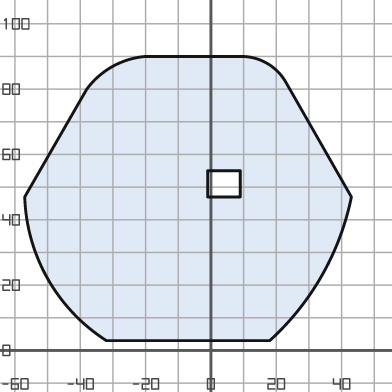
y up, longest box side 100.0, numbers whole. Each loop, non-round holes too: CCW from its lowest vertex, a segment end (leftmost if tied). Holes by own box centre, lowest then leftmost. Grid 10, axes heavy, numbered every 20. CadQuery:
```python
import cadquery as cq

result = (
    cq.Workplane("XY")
    .moveTo(-32.0, 3.0)
    .lineTo(18.0, 3.0)
    .threePointArc((34.0, 23.0), (43.0, 47.0))
    .lineTo(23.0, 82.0)
    .threePointArc((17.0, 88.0), (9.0, 90.0))
    .lineTo(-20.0, 90.0)
    .threePointArc((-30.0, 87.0), (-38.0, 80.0))
    .lineTo(-57.0, 47.0)
    .threePointArc((-50.0, 22.0), (-32.0, 3.0))
    .close()
    .moveTo(-1.0, 47.0)
    .lineTo(9.0, 47.0)
    .lineTo(9.0, 55.0)
    .lineTo(-1.0, 55.0)
    .close()
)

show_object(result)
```